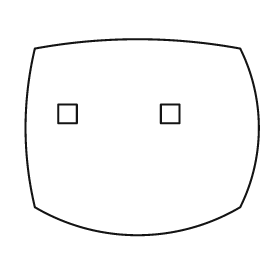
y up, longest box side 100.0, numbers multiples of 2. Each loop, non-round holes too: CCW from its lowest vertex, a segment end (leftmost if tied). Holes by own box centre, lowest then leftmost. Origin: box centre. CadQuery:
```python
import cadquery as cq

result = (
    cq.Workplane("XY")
    .moveTo(-46.0, -30.0)
    .threePointArc((-2.0, -42.0), (42.0, -30.0))
    .threePointArc((50.0, 4.0), (42.0, 38.0))
    .threePointArc((-2.0, 42.0), (-46.0, 38.0))
    .threePointArc((-50.0, 4.0), (-46.0, -30.0))
    .close()
    .moveTo(-36.0, 6.0)
    .lineTo(-28.0, 6.0)
    .lineTo(-28.0, 14.0)
    .lineTo(-36.0, 14.0)
    .close()
    .moveTo(8.0, 6.0)
    .lineTo(16.0, 6.0)
    .lineTo(16.0, 14.0)
    .lineTo(8.0, 14.0)
    .close()
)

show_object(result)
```